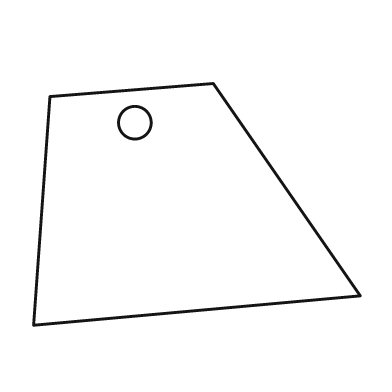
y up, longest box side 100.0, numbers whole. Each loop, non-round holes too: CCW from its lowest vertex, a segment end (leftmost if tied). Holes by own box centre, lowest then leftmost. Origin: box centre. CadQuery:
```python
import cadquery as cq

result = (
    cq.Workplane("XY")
    .moveTo(-50.0, -37.0)
    .lineTo(50.0, -28.0)
    .lineTo(5.0, 37.0)
    .lineTo(-45.0, 33.0)
    .close()
    .moveTo(-19.0, 25.0)
    .circle(5.0)
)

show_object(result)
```